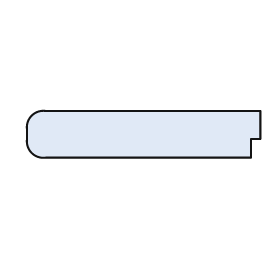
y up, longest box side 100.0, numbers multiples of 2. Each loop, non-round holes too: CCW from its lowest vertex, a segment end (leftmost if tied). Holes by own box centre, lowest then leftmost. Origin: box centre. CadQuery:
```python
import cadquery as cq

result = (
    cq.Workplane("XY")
    .moveTo(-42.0, -10.0)
    .lineTo(46.0, -10.0)
    .lineTo(46.0, -2.0)
    .lineTo(50.0, -2.0)
    .lineTo(50.0, 10.0)
    .lineTo(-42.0, 10.0)
    .threePointArc((-48.0, 8.0), (-50.0, 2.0))
    .lineTo(-50.0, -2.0)
    .threePointArc((-48.0, -8.0), (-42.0, -10.0))
    .close()
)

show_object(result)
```